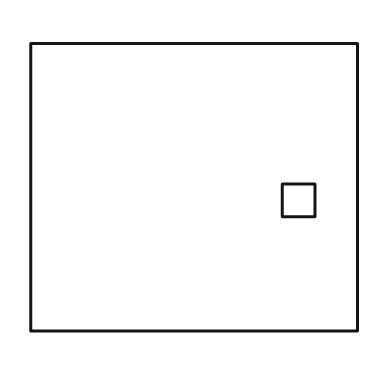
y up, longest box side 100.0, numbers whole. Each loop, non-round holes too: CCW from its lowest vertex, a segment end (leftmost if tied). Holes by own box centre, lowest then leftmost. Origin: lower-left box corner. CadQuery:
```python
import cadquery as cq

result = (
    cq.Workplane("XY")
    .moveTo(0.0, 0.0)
    .lineTo(100.0, 0.0)
    .lineTo(100.0, 88.0)
    .lineTo(0.0, 88.0)
    .close()
    .moveTo(77.0, 35.0)
    .lineTo(87.0, 35.0)
    .lineTo(87.0, 45.0)
    .lineTo(77.0, 45.0)
    .close()
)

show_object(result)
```